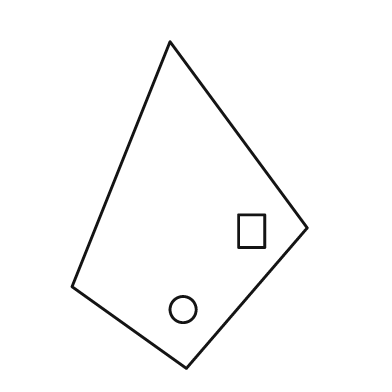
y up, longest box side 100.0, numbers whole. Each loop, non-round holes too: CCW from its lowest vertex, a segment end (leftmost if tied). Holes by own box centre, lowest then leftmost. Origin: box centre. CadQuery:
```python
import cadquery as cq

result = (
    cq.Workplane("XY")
    .moveTo(-1.0, -50.0)
    .lineTo(36.0, -7.0)
    .lineTo(-6.0, 50.0)
    .lineTo(-36.0, -25.0)
    .close()
    .moveTo(-2.0, -32.0)
    .circle(4.0)
    .moveTo(15.0, -13.0)
    .lineTo(23.0, -13.0)
    .lineTo(23.0, -3.0)
    .lineTo(15.0, -3.0)
    .close()
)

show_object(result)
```